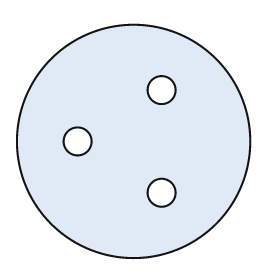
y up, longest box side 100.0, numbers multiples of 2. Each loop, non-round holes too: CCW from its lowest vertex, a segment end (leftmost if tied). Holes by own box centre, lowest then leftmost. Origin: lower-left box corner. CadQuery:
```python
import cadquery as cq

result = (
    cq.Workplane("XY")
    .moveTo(50.0, 50.0)
    .circle(50.0)
    .moveTo(62.0, 28.0)
    .circle(6.0)
    .moveTo(26.0, 50.0)
    .circle(6.0)
    .moveTo(62.0, 72.0)
    .circle(6.0)
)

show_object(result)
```